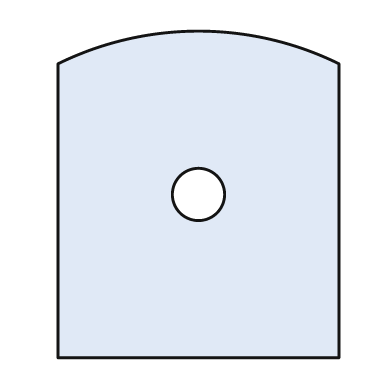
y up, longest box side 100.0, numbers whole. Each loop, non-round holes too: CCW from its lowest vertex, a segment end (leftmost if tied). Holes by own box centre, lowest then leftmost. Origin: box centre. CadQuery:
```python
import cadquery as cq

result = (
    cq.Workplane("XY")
    .moveTo(-43.0, -50.0)
    .lineTo(43.0, -50.0)
    .lineTo(43.0, 40.0)
    .threePointArc((0.0, 50.0), (-43.0, 40.0))
    .close()
    .moveTo(0.0, 0.0)
    .circle(8.0)
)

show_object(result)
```